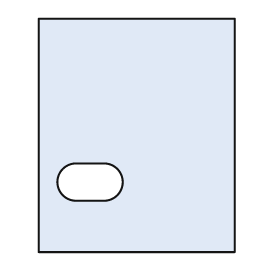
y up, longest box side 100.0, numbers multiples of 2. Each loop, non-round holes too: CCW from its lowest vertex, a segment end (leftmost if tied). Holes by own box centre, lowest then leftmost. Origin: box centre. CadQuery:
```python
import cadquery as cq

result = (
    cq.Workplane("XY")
    .moveTo(-42.0, -50.0)
    .lineTo(42.0, -50.0)
    .lineTo(42.0, 50.0)
    .lineTo(-42.0, 50.0)
    .close()
    .moveTo(-26.0, -28.0)
    .lineTo(-14.0, -28.0)
    .threePointArc((-6.0, -20.0), (-14.0, -12.0))
    .lineTo(-26.0, -12.0)
    .threePointArc((-34.0, -20.0), (-26.0, -28.0))
    .close()
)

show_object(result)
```